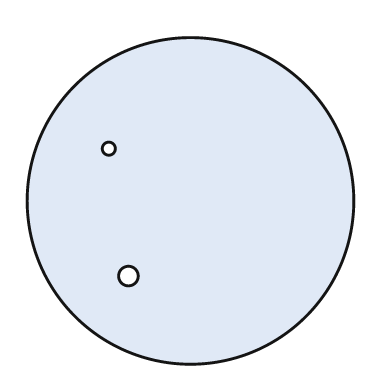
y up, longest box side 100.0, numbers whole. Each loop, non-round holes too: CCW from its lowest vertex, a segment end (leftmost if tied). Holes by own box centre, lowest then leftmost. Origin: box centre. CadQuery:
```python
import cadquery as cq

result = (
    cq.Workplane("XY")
    .moveTo(0.0, 0.0)
    .circle(50.0)
    .moveTo(-19.0, -23.0)
    .circle(3.0)
    .moveTo(-25.0, 16.0)
    .circle(2.0)
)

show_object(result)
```